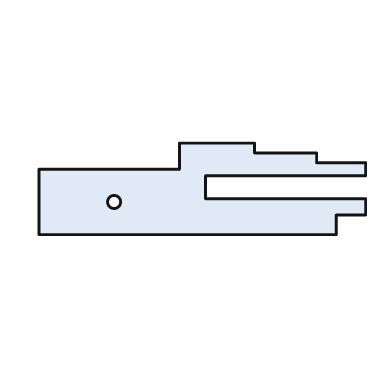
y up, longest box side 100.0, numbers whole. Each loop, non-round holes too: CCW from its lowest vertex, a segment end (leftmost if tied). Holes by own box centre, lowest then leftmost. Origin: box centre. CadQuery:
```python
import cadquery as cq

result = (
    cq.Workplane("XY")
    .moveTo(-50.0, -14.0)
    .lineTo(41.0, -14.0)
    .lineTo(41.0, -8.0)
    .lineTo(50.0, -8.0)
    .lineTo(50.0, -3.0)
    .lineTo(1.0, -3.0)
    .lineTo(1.0, 4.0)
    .lineTo(50.0, 4.0)
    .lineTo(50.0, 8.0)
    .lineTo(35.0, 8.0)
    .lineTo(35.0, 11.0)
    .lineTo(16.0, 11.0)
    .lineTo(16.0, 14.0)
    .lineTo(-7.0, 14.0)
    .lineTo(-7.0, 6.0)
    .lineTo(-50.0, 6.0)
    .close()
    .moveTo(-27.0, -4.0)
    .circle(2.0)
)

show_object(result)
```